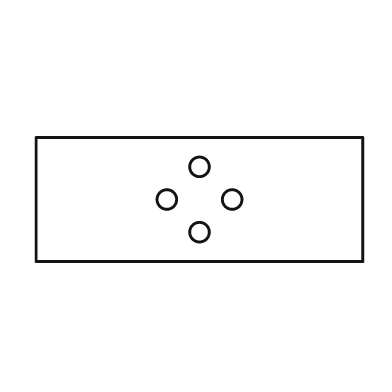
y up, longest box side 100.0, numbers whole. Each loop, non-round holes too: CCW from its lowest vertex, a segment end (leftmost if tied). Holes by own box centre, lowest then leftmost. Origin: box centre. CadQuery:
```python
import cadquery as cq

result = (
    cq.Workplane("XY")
    .moveTo(-50.0, -19.0)
    .lineTo(50.0, -19.0)
    .lineTo(50.0, 19.0)
    .lineTo(-50.0, 19.0)
    .close()
    .moveTo(0.0, -10.0)
    .circle(3.0)
    .moveTo(-10.0, 0.0)
    .circle(3.0)
    .moveTo(10.0, 0.0)
    .circle(3.0)
    .moveTo(0.0, 10.0)
    .circle(3.0)
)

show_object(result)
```